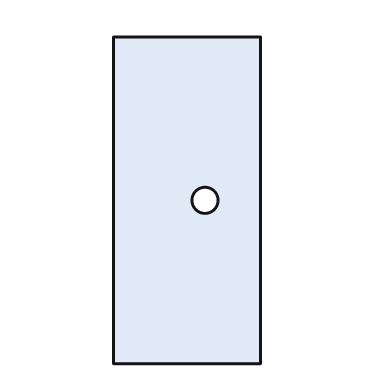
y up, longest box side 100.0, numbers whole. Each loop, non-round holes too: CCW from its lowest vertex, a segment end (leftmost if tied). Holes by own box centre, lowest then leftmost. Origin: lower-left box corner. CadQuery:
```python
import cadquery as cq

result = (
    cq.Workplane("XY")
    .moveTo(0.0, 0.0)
    .lineTo(45.0, 0.0)
    .lineTo(45.0, 100.0)
    .lineTo(0.0, 100.0)
    .close()
    .moveTo(28.0, 50.0)
    .circle(4.0)
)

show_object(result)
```